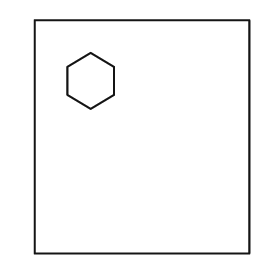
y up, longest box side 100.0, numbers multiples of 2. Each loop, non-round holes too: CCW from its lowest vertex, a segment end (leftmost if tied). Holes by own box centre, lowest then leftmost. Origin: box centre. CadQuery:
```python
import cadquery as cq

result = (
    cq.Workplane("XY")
    .moveTo(-46.0, -50.0)
    .lineTo(46.0, -50.0)
    .lineTo(46.0, 50.0)
    .lineTo(-46.0, 50.0)
    .close()
    .moveTo(-22.0, 12.0)
    .lineTo(-12.0, 18.0)
    .lineTo(-12.0, 30.0)
    .lineTo(-22.0, 36.0)
    .lineTo(-32.0, 30.0)
    .lineTo(-32.0, 18.0)
    .close()
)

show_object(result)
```